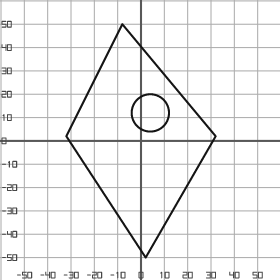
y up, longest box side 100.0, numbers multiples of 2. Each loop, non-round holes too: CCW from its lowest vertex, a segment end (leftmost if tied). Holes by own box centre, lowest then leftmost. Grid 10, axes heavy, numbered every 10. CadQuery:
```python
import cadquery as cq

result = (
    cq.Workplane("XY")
    .moveTo(2.0, -50.0)
    .lineTo(32.0, 2.0)
    .lineTo(-8.0, 50.0)
    .lineTo(-32.0, 2.0)
    .close()
    .moveTo(4.0, 12.0)
    .circle(8.0)
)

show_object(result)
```